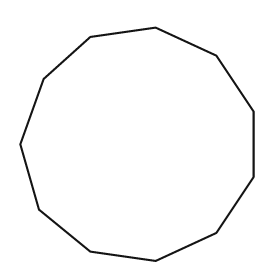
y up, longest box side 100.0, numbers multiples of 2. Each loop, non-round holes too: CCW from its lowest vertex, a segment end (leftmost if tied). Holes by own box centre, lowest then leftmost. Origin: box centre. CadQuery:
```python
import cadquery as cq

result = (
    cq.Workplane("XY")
    .moveTo(8.0, -50.0)
    .lineTo(34.0, -38.0)
    .lineTo(50.0, -14.0)
    .lineTo(50.0, 14.0)
    .lineTo(34.0, 38.0)
    .lineTo(8.0, 50.0)
    .lineTo(-20.0, 46.0)
    .lineTo(-40.0, 28.0)
    .lineTo(-50.0, 0.0)
    .lineTo(-42.0, -28.0)
    .lineTo(-20.0, -46.0)
    .close()
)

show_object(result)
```